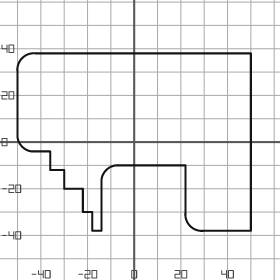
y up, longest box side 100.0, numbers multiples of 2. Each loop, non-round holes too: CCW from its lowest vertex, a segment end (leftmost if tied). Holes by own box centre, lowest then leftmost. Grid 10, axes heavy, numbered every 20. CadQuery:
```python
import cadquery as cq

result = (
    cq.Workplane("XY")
    .moveTo(-18.0, -38.0)
    .lineTo(-14.0, -38.0)
    .lineTo(-14.0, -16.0)
    .threePointArc((-12.0, -12.0), (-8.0, -10.0))
    .lineTo(22.0, -10.0)
    .lineTo(22.0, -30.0)
    .threePointArc((24.0, -36.0), (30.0, -38.0))
    .lineTo(50.0, -38.0)
    .lineTo(50.0, 38.0)
    .lineTo(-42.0, 38.0)
    .threePointArc((-48.0, 36.0), (-50.0, 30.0))
    .lineTo(-50.0, 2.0)
    .threePointArc((-48.0, -2.0), (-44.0, -4.0))
    .lineTo(-36.0, -4.0)
    .lineTo(-36.0, -12.0)
    .lineTo(-30.0, -12.0)
    .lineTo(-30.0, -20.0)
    .lineTo(-22.0, -20.0)
    .lineTo(-22.0, -30.0)
    .lineTo(-18.0, -30.0)
    .close()
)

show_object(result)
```